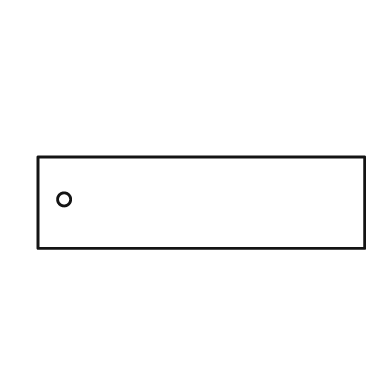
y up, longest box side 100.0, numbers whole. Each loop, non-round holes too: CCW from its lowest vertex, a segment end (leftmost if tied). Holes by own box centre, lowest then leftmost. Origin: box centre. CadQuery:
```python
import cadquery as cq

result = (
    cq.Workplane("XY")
    .moveTo(-50.0, -14.0)
    .lineTo(50.0, -14.0)
    .lineTo(50.0, 14.0)
    .lineTo(-50.0, 14.0)
    .close()
    .moveTo(-42.0, 1.0)
    .circle(2.0)
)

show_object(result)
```